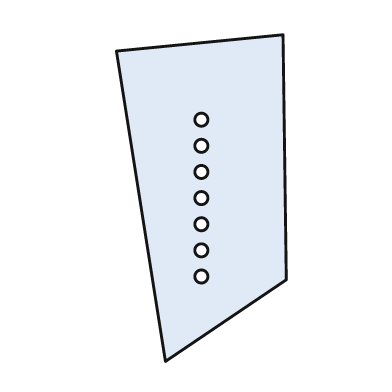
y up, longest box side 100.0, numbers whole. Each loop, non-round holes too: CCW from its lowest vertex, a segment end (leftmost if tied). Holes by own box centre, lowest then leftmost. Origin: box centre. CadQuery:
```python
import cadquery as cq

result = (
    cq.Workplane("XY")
    .moveTo(-11.0, -50.0)
    .lineTo(26.0, -25.0)
    .lineTo(25.0, 50.0)
    .lineTo(-26.0, 45.0)
    .close()
    .moveTo(0.0, -24.0)
    .circle(2.0)
    .moveTo(0.0, -16.0)
    .circle(2.0)
    .moveTo(0.0, -8.0)
    .circle(2.0)
    .moveTo(0.0, 0.0)
    .circle(2.0)
    .moveTo(0.0, 8.0)
    .circle(2.0)
    .moveTo(0.0, 16.0)
    .circle(2.0)
    .moveTo(0.0, 24.0)
    .circle(2.0)
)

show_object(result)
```